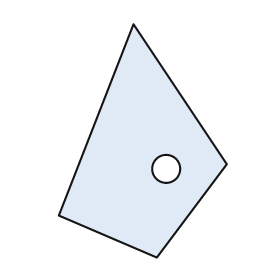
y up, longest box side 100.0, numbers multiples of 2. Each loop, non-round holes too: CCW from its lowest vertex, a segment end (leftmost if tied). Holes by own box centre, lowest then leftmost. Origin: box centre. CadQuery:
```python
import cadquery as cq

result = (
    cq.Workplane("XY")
    .moveTo(6.0, -50.0)
    .lineTo(36.0, -10.0)
    .lineTo(-4.0, 50.0)
    .lineTo(-36.0, -32.0)
    .close()
    .moveTo(10.0, -12.0)
    .circle(6.0)
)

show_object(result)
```